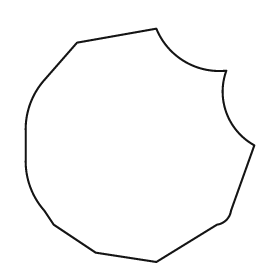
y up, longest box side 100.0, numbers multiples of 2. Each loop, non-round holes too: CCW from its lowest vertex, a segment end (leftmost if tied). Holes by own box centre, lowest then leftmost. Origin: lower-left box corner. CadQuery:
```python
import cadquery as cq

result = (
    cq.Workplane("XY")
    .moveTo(56.0, 0.0)
    .lineTo(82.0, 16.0)
    .threePointArc((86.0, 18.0), (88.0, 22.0))
    .lineTo(98.0, 50.0)
    .threePointArc((86.0, 64.0), (86.0, 82.0))
    .threePointArc((68.0, 86.0), (56.0, 100.0))
    .lineTo(22.0, 94.0)
    .lineTo(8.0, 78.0)
    .threePointArc((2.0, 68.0), (0.0, 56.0))
    .lineTo(0.0, 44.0)
    .threePointArc((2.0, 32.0), (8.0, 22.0))
    .lineTo(12.0, 16.0)
    .lineTo(30.0, 4.0)
    .close()
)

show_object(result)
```